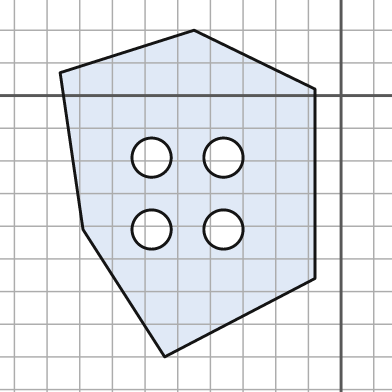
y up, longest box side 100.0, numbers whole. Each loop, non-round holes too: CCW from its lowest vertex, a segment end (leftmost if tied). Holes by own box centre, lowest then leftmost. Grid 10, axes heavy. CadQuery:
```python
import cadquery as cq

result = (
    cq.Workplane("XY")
    .moveTo(-54.0, -80.0)
    .lineTo(-8.0, -56.0)
    .lineTo(-8.0, 2.0)
    .lineTo(-45.0, 20.0)
    .lineTo(-86.0, 7.0)
    .lineTo(-79.0, -41.0)
    .close()
    .moveTo(-58.0, -41.0)
    .circle(6.0)
    .moveTo(-36.0, -41.0)
    .circle(6.0)
    .moveTo(-58.0, -19.0)
    .circle(6.0)
    .moveTo(-36.0, -19.0)
    .circle(6.0)
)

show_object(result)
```